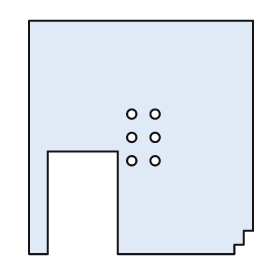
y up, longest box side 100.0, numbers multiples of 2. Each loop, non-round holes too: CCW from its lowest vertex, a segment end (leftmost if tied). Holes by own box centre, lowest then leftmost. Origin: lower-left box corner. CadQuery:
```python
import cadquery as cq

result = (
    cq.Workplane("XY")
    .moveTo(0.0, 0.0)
    .lineTo(8.0, 0.0)
    .lineTo(8.0, 44.0)
    .lineTo(38.0, 44.0)
    .lineTo(38.0, 0.0)
    .lineTo(88.0, 0.0)
    .lineTo(88.0, 4.0)
    .lineTo(92.0, 4.0)
    .lineTo(92.0, 10.0)
    .lineTo(96.0, 10.0)
    .lineTo(96.0, 100.0)
    .lineTo(0.0, 100.0)
    .close()
    .moveTo(44.0, 40.0)
    .circle(2.0)
    .moveTo(54.0, 40.0)
    .circle(2.0)
    .moveTo(44.0, 50.0)
    .circle(2.0)
    .moveTo(54.0, 50.0)
    .circle(2.0)
    .moveTo(44.0, 60.0)
    .circle(2.0)
    .moveTo(54.0, 60.0)
    .circle(2.0)
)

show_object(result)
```